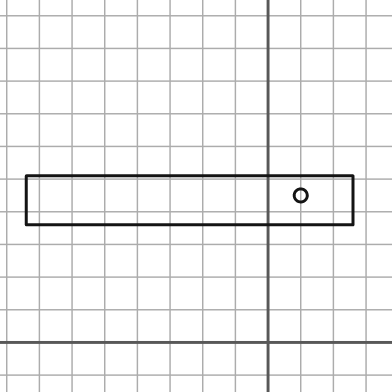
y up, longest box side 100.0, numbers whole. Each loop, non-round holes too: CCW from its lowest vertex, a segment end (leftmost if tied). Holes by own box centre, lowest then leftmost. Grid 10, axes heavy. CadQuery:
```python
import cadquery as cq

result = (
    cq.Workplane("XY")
    .moveTo(-74.0, 36.0)
    .lineTo(26.0, 36.0)
    .lineTo(26.0, 51.0)
    .lineTo(-74.0, 51.0)
    .close()
    .moveTo(10.0, 45.0)
    .circle(2.0)
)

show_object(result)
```